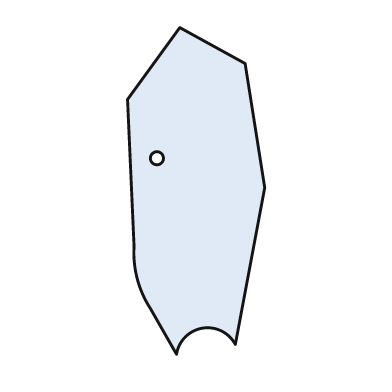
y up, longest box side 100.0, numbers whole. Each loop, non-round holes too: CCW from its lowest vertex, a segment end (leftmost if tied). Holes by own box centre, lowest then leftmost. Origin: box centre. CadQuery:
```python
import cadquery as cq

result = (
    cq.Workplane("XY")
    .moveTo(-6.0, -50.0)
    .threePointArc((2.0, -42.0), (12.0, -47.0))
    .lineTo(21.0, 1.0)
    .lineTo(15.0, 39.0)
    .lineTo(-5.0, 50.0)
    .lineTo(-21.0, 28.0)
    .lineTo(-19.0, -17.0)
    .threePointArc((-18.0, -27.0), (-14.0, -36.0))
    .close()
    .moveTo(-12.0, 10.0)
    .circle(2.0)
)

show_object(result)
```